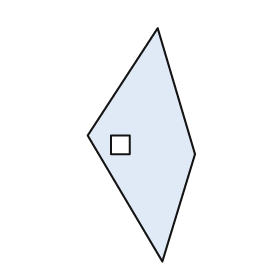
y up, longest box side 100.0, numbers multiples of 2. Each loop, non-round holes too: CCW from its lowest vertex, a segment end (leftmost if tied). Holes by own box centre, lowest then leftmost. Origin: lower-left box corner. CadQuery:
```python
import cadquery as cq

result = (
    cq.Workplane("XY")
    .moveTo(32.0, 0.0)
    .lineTo(46.0, 46.0)
    .lineTo(30.0, 100.0)
    .lineTo(0.0, 54.0)
    .close()
    .moveTo(10.0, 46.0)
    .lineTo(18.0, 46.0)
    .lineTo(18.0, 54.0)
    .lineTo(10.0, 54.0)
    .close()
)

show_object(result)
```